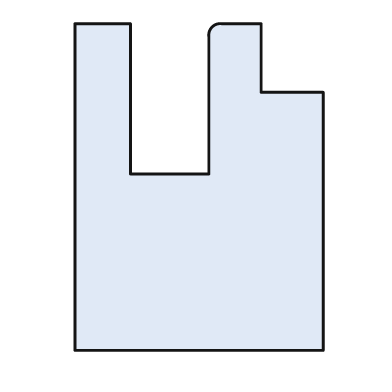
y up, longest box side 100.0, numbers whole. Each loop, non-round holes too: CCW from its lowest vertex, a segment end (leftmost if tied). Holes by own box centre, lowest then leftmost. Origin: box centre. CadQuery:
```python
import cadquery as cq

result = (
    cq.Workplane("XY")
    .moveTo(-38.0, -50.0)
    .lineTo(38.0, -50.0)
    .lineTo(38.0, 29.0)
    .lineTo(19.0, 29.0)
    .lineTo(19.0, 50.0)
    .lineTo(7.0, 50.0)
    .threePointArc((4.0, 49.0), (3.0, 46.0))
    .lineTo(3.0, 4.0)
    .lineTo(-21.0, 4.0)
    .lineTo(-21.0, 50.0)
    .lineTo(-38.0, 50.0)
    .close()
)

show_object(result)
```